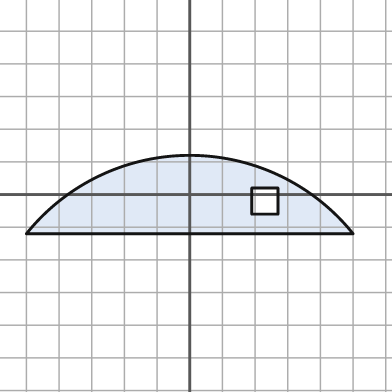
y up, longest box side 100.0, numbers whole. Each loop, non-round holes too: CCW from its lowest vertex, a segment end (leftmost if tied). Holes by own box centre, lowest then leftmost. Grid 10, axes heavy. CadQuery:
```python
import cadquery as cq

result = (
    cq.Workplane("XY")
    .moveTo(-50.0, -12.0)
    .lineTo(50.0, -12.0)
    .threePointArc((0.0, 12.0), (-50.0, -12.0))
    .close()
    .moveTo(19.0, -6.0)
    .lineTo(27.0, -6.0)
    .lineTo(27.0, 2.0)
    .lineTo(19.0, 2.0)
    .close()
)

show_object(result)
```